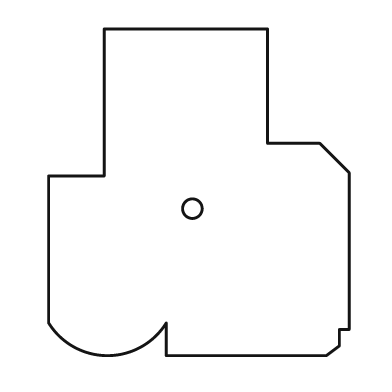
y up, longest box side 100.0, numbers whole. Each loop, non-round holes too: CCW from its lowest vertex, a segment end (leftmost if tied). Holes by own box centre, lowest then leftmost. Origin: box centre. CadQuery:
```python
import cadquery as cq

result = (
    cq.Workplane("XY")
    .moveTo(-10.0, -50.0)
    .lineTo(39.0, -50.0)
    .lineTo(43.0, -47.0)
    .lineTo(43.0, -42.0)
    .lineTo(46.0, -42.0)
    .lineTo(46.0, 6.0)
    .lineTo(37.0, 15.0)
    .lineTo(21.0, 15.0)
    .lineTo(21.0, 50.0)
    .lineTo(-29.0, 50.0)
    .lineTo(-29.0, 5.0)
    .lineTo(-46.0, 5.0)
    .lineTo(-46.0, -40.0)
    .threePointArc((-28.0, -50.0), (-10.0, -40.0))
    .close()
    .moveTo(-2.0, -5.0)
    .circle(3.0)
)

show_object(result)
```